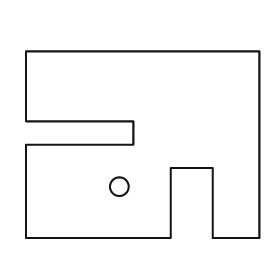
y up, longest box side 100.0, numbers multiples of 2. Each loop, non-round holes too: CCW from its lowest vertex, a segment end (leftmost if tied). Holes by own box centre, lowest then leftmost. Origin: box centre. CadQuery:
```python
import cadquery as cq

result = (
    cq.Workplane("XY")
    .moveTo(-50.0, -40.0)
    .lineTo(12.0, -40.0)
    .lineTo(12.0, -10.0)
    .lineTo(30.0, -10.0)
    .lineTo(30.0, -40.0)
    .lineTo(50.0, -40.0)
    .lineTo(50.0, 40.0)
    .lineTo(-50.0, 40.0)
    .lineTo(-50.0, 10.0)
    .lineTo(-4.0, 10.0)
    .lineTo(-4.0, 0.0)
    .lineTo(-50.0, 0.0)
    .close()
    .moveTo(-10.0, -18.0)
    .circle(4.0)
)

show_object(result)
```